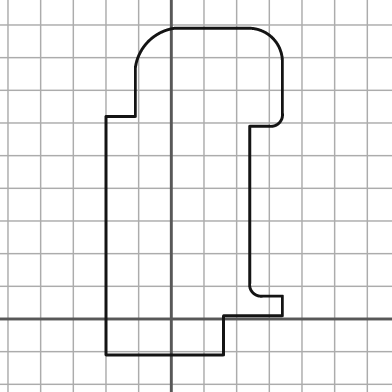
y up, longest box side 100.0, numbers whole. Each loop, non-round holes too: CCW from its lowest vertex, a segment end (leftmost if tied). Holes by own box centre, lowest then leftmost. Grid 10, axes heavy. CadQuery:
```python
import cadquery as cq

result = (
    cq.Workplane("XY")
    .moveTo(-20.0, -11.0)
    .lineTo(16.0, -11.0)
    .lineTo(16.0, 1.0)
    .lineTo(34.0, 1.0)
    .lineTo(34.0, 7.0)
    .lineTo(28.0, 7.0)
    .threePointArc((25.0, 8.0), (24.0, 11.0))
    .lineTo(24.0, 59.0)
    .lineTo(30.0, 59.0)
    .threePointArc((33.0, 60.0), (34.0, 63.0))
    .lineTo(34.0, 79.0)
    .threePointArc((31.0, 86.0), (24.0, 89.0))
    .lineTo(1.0, 89.0)
    .threePointArc((-7.0, 85.0), (-11.0, 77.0))
    .lineTo(-11.0, 62.0)
    .lineTo(-20.0, 62.0)
    .close()
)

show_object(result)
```